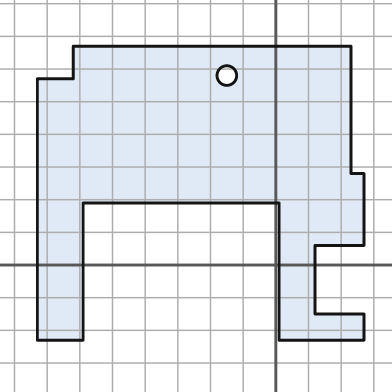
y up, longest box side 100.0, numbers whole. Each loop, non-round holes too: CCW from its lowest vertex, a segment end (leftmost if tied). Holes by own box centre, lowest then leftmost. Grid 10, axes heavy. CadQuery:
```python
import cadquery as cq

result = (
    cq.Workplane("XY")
    .moveTo(-73.0, -23.0)
    .lineTo(-59.0, -23.0)
    .lineTo(-59.0, 19.0)
    .lineTo(1.0, 19.0)
    .lineTo(1.0, -23.0)
    .lineTo(27.0, -23.0)
    .lineTo(27.0, -15.0)
    .lineTo(12.0, -15.0)
    .lineTo(12.0, 6.0)
    .lineTo(27.0, 6.0)
    .lineTo(27.0, 28.0)
    .lineTo(23.0, 28.0)
    .lineTo(23.0, 67.0)
    .lineTo(-62.0, 67.0)
    .lineTo(-62.0, 57.0)
    .lineTo(-73.0, 57.0)
    .close()
    .moveTo(-15.0, 58.0)
    .circle(3.0)
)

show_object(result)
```